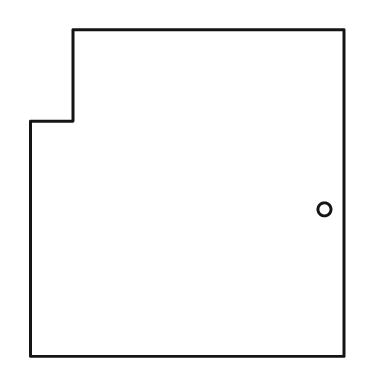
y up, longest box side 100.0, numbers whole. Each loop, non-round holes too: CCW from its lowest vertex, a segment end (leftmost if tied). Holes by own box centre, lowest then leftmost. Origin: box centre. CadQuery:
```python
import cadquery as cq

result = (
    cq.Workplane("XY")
    .moveTo(-48.0, -50.0)
    .lineTo(48.0, -50.0)
    .lineTo(48.0, 50.0)
    .lineTo(-35.0, 50.0)
    .lineTo(-35.0, 22.0)
    .lineTo(-48.0, 22.0)
    .close()
    .moveTo(42.0, -5.0)
    .circle(2.0)
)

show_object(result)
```